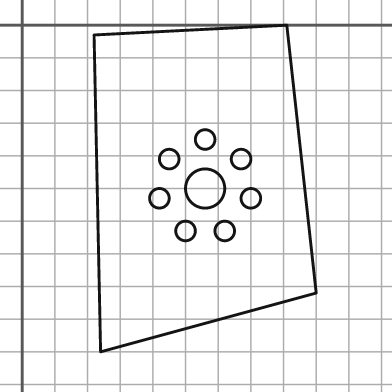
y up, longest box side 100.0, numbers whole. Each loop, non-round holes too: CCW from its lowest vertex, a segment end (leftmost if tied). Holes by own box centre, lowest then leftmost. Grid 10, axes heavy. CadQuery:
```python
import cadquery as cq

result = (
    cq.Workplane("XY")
    .moveTo(24.0, -100.0)
    .lineTo(90.0, -82.0)
    .lineTo(81.0, 0.0)
    .lineTo(22.0, -3.0)
    .close()
    .moveTo(50.0, -63.0)
    .circle(3.0)
    .moveTo(62.0, -63.0)
    .circle(3.0)
    .moveTo(42.0, -53.0)
    .circle(3.0)
    .moveTo(70.0, -53.0)
    .circle(3.0)
    .moveTo(56.0, -50.0)
    .circle(6.0)
    .moveTo(45.0, -41.0)
    .circle(3.0)
    .moveTo(67.0, -41.0)
    .circle(3.0)
    .moveTo(56.0, -35.0)
    .circle(3.0)
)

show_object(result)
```